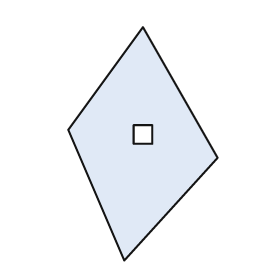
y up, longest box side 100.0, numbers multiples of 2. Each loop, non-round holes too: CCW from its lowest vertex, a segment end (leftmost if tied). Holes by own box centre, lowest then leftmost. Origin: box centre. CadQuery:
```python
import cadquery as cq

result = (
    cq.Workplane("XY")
    .moveTo(-8.0, -50.0)
    .lineTo(32.0, -6.0)
    .lineTo(0.0, 50.0)
    .lineTo(-32.0, 6.0)
    .close()
    .moveTo(-4.0, 0.0)
    .lineTo(4.0, 0.0)
    .lineTo(4.0, 8.0)
    .lineTo(-4.0, 8.0)
    .close()
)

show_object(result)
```